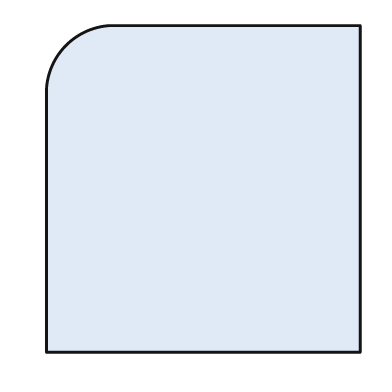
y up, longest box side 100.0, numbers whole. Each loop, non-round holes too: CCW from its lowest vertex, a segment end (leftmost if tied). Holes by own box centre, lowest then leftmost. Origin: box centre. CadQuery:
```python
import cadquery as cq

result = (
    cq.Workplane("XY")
    .moveTo(-48.0, -50.0)
    .lineTo(48.0, -50.0)
    .lineTo(48.0, 50.0)
    .lineTo(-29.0, 50.0)
    .threePointArc((-42.0, 44.0), (-48.0, 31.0))
    .close()
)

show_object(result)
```